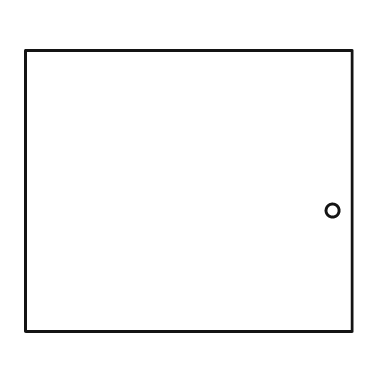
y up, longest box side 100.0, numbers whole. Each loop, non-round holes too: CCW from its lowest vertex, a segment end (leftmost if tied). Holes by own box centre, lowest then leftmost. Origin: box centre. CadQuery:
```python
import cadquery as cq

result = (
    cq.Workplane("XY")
    .moveTo(-50.0, -43.0)
    .lineTo(50.0, -43.0)
    .lineTo(50.0, 43.0)
    .lineTo(-50.0, 43.0)
    .close()
    .moveTo(44.0, -6.0)
    .circle(2.0)
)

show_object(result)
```